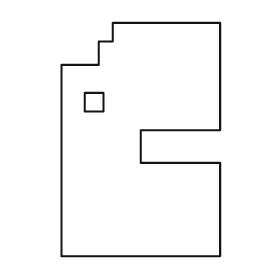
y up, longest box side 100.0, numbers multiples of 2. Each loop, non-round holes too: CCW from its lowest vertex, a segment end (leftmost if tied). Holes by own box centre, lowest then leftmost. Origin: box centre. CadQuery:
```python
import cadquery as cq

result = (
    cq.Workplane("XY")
    .moveTo(-34.0, -50.0)
    .lineTo(34.0, -50.0)
    .lineTo(34.0, -10.0)
    .lineTo(0.0, -10.0)
    .lineTo(0.0, 4.0)
    .lineTo(34.0, 4.0)
    .lineTo(34.0, 50.0)
    .lineTo(-12.0, 50.0)
    .lineTo(-12.0, 42.0)
    .lineTo(-18.0, 42.0)
    .lineTo(-18.0, 32.0)
    .lineTo(-34.0, 32.0)
    .close()
    .moveTo(-24.0, 12.0)
    .lineTo(-16.0, 12.0)
    .lineTo(-16.0, 20.0)
    .lineTo(-24.0, 20.0)
    .close()
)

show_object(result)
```